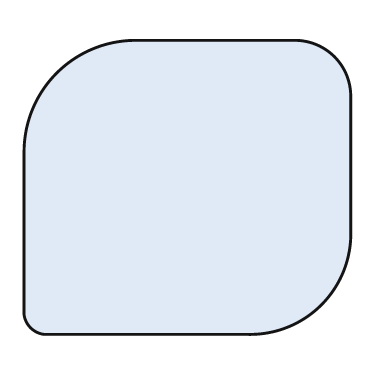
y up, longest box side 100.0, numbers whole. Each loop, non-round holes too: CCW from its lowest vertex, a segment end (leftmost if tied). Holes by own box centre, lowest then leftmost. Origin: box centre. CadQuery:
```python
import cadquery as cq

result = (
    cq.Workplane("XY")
    .moveTo(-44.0, -45.0)
    .lineTo(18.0, -45.0)
    .threePointArc((41.0, -36.0), (50.0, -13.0))
    .lineTo(50.0, 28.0)
    .threePointArc((45.0, 40.0), (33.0, 45.0))
    .lineTo(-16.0, 45.0)
    .threePointArc((-40.0, 35.0), (-50.0, 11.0))
    .lineTo(-50.0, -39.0)
    .threePointArc((-48.0, -43.0), (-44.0, -45.0))
    .close()
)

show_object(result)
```